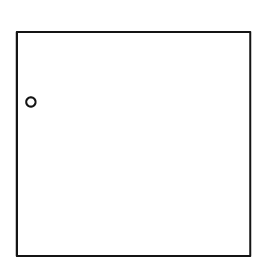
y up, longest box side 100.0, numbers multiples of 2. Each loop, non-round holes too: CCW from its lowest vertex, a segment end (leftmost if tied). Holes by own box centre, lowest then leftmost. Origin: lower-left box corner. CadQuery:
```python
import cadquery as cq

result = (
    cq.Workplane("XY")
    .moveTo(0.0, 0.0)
    .lineTo(100.0, 0.0)
    .lineTo(100.0, 96.0)
    .lineTo(0.0, 96.0)
    .close()
    .moveTo(6.0, 66.0)
    .circle(2.0)
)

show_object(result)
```